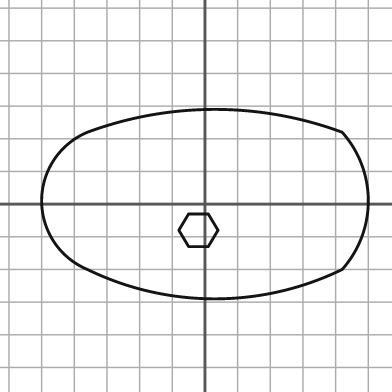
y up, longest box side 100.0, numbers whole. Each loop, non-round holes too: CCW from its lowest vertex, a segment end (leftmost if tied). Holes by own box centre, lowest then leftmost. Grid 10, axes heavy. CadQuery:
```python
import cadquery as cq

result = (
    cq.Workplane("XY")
    .moveTo(-36.0, -20.0)
    .threePointArc((3.0, -29.0), (42.0, -20.0))
    .threePointArc((50.0, 1.0), (42.0, 22.0))
    .threePointArc((3.0, 29.0), (-36.0, 22.0))
    .threePointArc((-50.0, 1.0), (-36.0, -20.0))
    .close()
    .moveTo(-5.0, -13.0)
    .lineTo(1.0, -13.0)
    .lineTo(4.0, -8.0)
    .lineTo(1.0, -3.0)
    .lineTo(-5.0, -3.0)
    .lineTo(-8.0, -8.0)
    .close()
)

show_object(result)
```